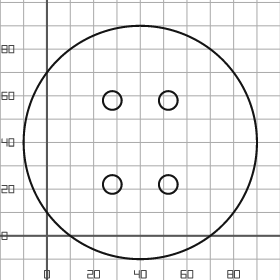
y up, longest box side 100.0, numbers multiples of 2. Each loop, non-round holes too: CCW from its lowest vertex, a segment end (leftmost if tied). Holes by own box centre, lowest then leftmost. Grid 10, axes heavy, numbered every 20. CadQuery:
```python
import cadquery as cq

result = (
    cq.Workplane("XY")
    .moveTo(40.0, 40.0)
    .circle(50.0)
    .moveTo(28.0, 22.0)
    .circle(4.0)
    .moveTo(52.0, 22.0)
    .circle(4.0)
    .moveTo(28.0, 58.0)
    .circle(4.0)
    .moveTo(52.0, 58.0)
    .circle(4.0)
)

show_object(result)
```